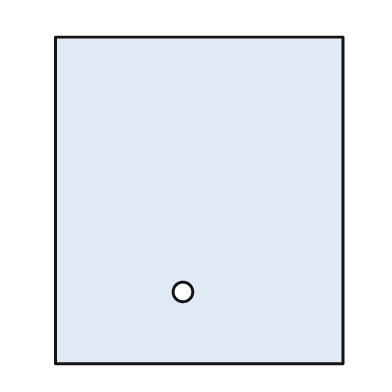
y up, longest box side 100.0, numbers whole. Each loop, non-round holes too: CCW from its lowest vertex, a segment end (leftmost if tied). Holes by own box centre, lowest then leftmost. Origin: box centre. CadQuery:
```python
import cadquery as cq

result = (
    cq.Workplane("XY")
    .moveTo(-44.0, -50.0)
    .lineTo(44.0, -50.0)
    .lineTo(44.0, 50.0)
    .lineTo(-44.0, 50.0)
    .close()
    .moveTo(-5.0, -28.0)
    .circle(3.0)
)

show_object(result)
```